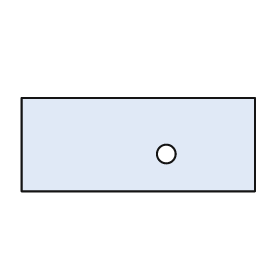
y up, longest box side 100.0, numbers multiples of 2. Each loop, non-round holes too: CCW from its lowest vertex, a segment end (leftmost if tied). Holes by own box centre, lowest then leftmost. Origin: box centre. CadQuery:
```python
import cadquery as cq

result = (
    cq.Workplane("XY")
    .moveTo(-50.0, -20.0)
    .lineTo(50.0, -20.0)
    .lineTo(50.0, 20.0)
    .lineTo(-50.0, 20.0)
    .close()
    .moveTo(12.0, -4.0)
    .circle(4.0)
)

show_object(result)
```